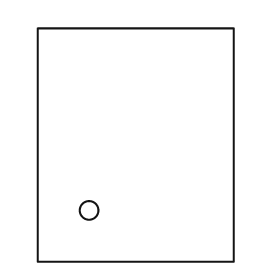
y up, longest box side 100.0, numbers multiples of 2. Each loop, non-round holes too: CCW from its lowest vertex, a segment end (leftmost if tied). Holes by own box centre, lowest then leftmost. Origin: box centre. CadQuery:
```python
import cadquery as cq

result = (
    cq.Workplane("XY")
    .moveTo(-42.0, -50.0)
    .lineTo(42.0, -50.0)
    .lineTo(42.0, 50.0)
    .lineTo(-42.0, 50.0)
    .close()
    .moveTo(-20.0, -28.0)
    .circle(4.0)
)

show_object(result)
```